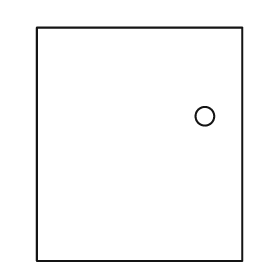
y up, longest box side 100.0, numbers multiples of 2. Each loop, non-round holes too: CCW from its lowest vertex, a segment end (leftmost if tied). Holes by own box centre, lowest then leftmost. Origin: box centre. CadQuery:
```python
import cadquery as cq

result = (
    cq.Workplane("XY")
    .moveTo(-44.0, -50.0)
    .lineTo(44.0, -50.0)
    .lineTo(44.0, 50.0)
    .lineTo(-44.0, 50.0)
    .close()
    .moveTo(28.0, 12.0)
    .circle(4.0)
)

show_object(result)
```